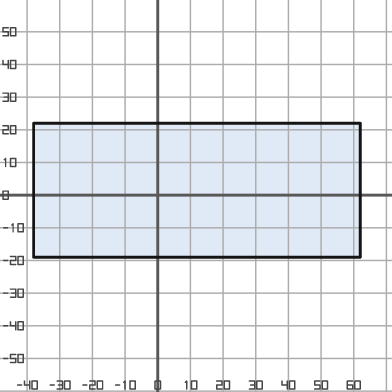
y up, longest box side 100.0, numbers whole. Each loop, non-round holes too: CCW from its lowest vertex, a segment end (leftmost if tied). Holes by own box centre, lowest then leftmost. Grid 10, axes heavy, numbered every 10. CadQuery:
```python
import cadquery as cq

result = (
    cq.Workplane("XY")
    .moveTo(-38.0, -19.0)
    .lineTo(62.0, -19.0)
    .lineTo(62.0, 22.0)
    .lineTo(-38.0, 22.0)
    .close()
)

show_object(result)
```